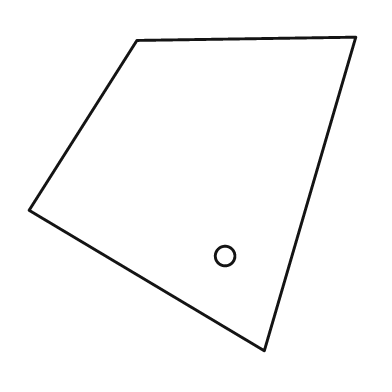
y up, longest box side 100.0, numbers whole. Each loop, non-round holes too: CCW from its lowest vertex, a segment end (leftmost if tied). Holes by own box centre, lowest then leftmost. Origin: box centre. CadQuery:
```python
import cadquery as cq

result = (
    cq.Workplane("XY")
    .moveTo(22.0, -48.0)
    .lineTo(50.0, 48.0)
    .lineTo(-17.0, 47.0)
    .lineTo(-50.0, -5.0)
    .close()
    .moveTo(10.0, -19.0)
    .circle(3.0)
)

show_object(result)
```